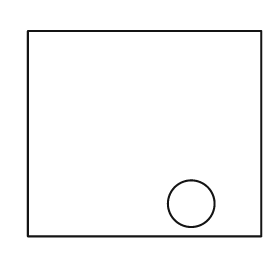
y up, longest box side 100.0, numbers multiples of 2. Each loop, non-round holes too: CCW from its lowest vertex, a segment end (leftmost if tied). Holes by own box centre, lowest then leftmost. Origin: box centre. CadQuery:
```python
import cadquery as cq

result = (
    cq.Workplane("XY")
    .moveTo(-50.0, -44.0)
    .lineTo(50.0, -44.0)
    .lineTo(50.0, 44.0)
    .lineTo(-50.0, 44.0)
    .close()
    .moveTo(20.0, -30.0)
    .circle(10.0)
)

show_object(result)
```